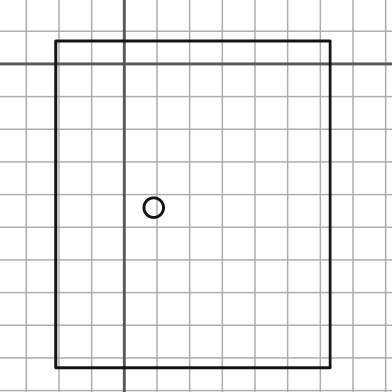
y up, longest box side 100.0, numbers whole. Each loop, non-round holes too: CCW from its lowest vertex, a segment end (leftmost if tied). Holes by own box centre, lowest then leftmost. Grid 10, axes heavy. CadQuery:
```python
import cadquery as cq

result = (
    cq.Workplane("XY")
    .moveTo(-21.0, -93.0)
    .lineTo(63.0, -93.0)
    .lineTo(63.0, 7.0)
    .lineTo(-21.0, 7.0)
    .close()
    .moveTo(9.0, -44.0)
    .circle(3.0)
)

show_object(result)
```